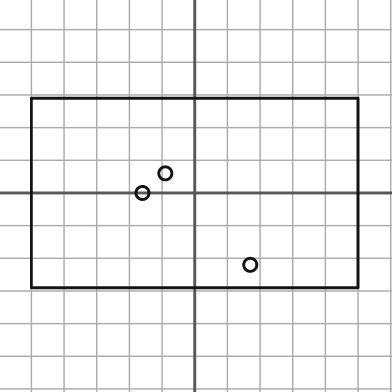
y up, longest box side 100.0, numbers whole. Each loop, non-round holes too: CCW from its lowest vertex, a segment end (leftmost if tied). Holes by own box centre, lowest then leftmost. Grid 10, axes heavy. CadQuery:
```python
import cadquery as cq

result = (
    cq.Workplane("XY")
    .moveTo(-50.0, -29.0)
    .lineTo(50.0, -29.0)
    .lineTo(50.0, 29.0)
    .lineTo(-50.0, 29.0)
    .close()
    .moveTo(17.0, -22.0)
    .circle(2.0)
    .moveTo(-16.0, 0.0)
    .circle(2.0)
    .moveTo(-9.0, 6.0)
    .circle(2.0)
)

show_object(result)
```